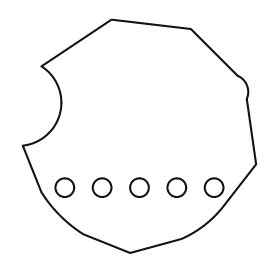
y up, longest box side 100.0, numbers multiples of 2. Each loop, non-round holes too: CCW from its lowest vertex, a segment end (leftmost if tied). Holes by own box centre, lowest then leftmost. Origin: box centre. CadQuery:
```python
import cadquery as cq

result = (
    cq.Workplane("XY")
    .moveTo(-4.0, -50.0)
    .lineTo(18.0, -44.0)
    .threePointArc((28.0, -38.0), (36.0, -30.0))
    .lineTo(50.0, -12.0)
    .lineTo(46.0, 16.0)
    .threePointArc((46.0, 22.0), (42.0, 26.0))
    .lineTo(22.0, 46.0)
    .lineTo(-12.0, 50.0)
    .lineTo(-42.0, 30.0)
    .threePointArc((-34.0, 10.0), (-50.0, -4.0))
    .lineTo(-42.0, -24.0)
    .threePointArc((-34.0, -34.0), (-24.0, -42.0))
    .close()
    .moveTo(-32.0, -22.0)
    .circle(4.0)
    .moveTo(-16.0, -22.0)
    .circle(4.0)
    .moveTo(0.0, -22.0)
    .circle(4.0)
    .moveTo(16.0, -22.0)
    .circle(4.0)
    .moveTo(32.0, -22.0)
    .circle(4.0)
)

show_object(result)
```